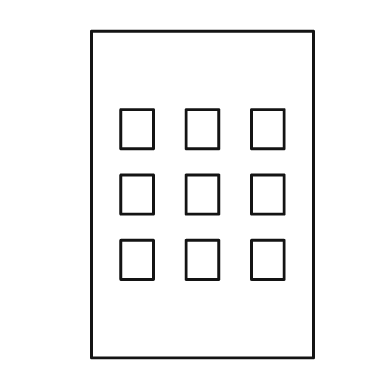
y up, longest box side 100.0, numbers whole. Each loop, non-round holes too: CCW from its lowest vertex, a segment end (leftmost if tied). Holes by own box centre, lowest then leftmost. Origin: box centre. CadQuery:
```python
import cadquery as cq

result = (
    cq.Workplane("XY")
    .moveTo(-34.0, -50.0)
    .lineTo(34.0, -50.0)
    .lineTo(34.0, 50.0)
    .lineTo(-34.0, 50.0)
    .close()
    .moveTo(-25.0, -26.0)
    .lineTo(-15.0, -26.0)
    .lineTo(-15.0, -14.0)
    .lineTo(-25.0, -14.0)
    .close()
    .moveTo(-5.0, -26.0)
    .lineTo(5.0, -26.0)
    .lineTo(5.0, -14.0)
    .lineTo(-5.0, -14.0)
    .close()
    .moveTo(15.0, -26.0)
    .lineTo(25.0, -26.0)
    .lineTo(25.0, -14.0)
    .lineTo(15.0, -14.0)
    .close()
    .moveTo(-25.0, -6.0)
    .lineTo(-15.0, -6.0)
    .lineTo(-15.0, 6.0)
    .lineTo(-25.0, 6.0)
    .close()
    .moveTo(-5.0, -6.0)
    .lineTo(5.0, -6.0)
    .lineTo(5.0, 6.0)
    .lineTo(-5.0, 6.0)
    .close()
    .moveTo(15.0, -6.0)
    .lineTo(25.0, -6.0)
    .lineTo(25.0, 6.0)
    .lineTo(15.0, 6.0)
    .close()
    .moveTo(-25.0, 14.0)
    .lineTo(-15.0, 14.0)
    .lineTo(-15.0, 26.0)
    .lineTo(-25.0, 26.0)
    .close()
    .moveTo(-5.0, 14.0)
    .lineTo(5.0, 14.0)
    .lineTo(5.0, 26.0)
    .lineTo(-5.0, 26.0)
    .close()
    .moveTo(15.0, 14.0)
    .lineTo(25.0, 14.0)
    .lineTo(25.0, 26.0)
    .lineTo(15.0, 26.0)
    .close()
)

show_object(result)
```